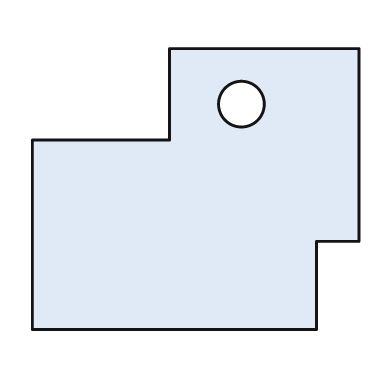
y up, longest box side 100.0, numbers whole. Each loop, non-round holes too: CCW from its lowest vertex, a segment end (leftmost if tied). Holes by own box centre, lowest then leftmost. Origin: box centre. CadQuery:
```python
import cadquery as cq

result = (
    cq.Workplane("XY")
    .moveTo(-50.0, -43.0)
    .lineTo(37.0, -43.0)
    .lineTo(37.0, -16.0)
    .lineTo(50.0, -16.0)
    .lineTo(50.0, 43.0)
    .lineTo(-8.0, 43.0)
    .lineTo(-8.0, 15.0)
    .lineTo(-50.0, 15.0)
    .close()
    .moveTo(14.0, 26.0)
    .circle(7.0)
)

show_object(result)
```